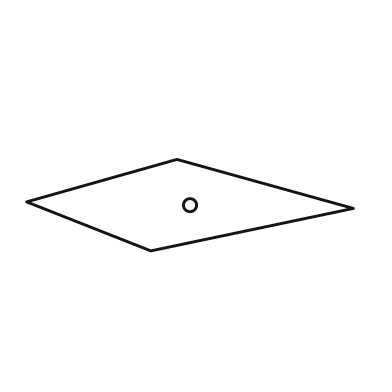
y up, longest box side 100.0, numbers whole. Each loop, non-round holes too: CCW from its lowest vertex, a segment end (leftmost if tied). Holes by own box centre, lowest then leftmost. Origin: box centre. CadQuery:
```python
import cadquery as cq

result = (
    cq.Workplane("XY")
    .moveTo(-12.0, -14.0)
    .lineTo(50.0, -1.0)
    .lineTo(-4.0, 14.0)
    .lineTo(-50.0, 1.0)
    .close()
    .moveTo(0.0, 0.0)
    .circle(2.0)
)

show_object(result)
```